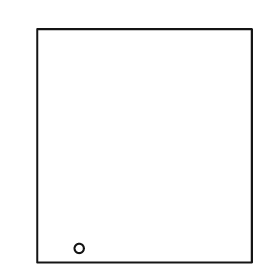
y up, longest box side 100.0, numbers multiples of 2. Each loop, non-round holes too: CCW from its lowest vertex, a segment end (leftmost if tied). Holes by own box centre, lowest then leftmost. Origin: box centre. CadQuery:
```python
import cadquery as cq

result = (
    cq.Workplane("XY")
    .moveTo(-46.0, -50.0)
    .lineTo(46.0, -50.0)
    .lineTo(46.0, 50.0)
    .lineTo(-46.0, 50.0)
    .close()
    .moveTo(-28.0, -44.0)
    .circle(2.0)
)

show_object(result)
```